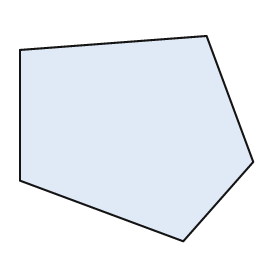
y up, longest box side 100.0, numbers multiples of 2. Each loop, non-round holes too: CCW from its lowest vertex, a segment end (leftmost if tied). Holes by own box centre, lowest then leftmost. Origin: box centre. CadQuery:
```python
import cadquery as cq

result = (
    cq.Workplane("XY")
    .moveTo(20.0, -44.0)
    .lineTo(50.0, -10.0)
    .lineTo(30.0, 44.0)
    .lineTo(-50.0, 38.0)
    .lineTo(-50.0, -18.0)
    .close()
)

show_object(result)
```